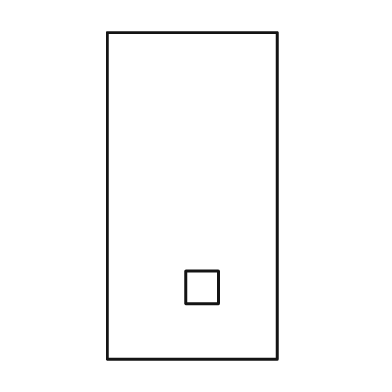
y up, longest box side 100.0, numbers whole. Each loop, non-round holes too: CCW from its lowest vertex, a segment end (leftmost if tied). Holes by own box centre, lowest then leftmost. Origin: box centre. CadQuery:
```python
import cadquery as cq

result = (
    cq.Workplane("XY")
    .moveTo(-26.0, -50.0)
    .lineTo(26.0, -50.0)
    .lineTo(26.0, 50.0)
    .lineTo(-26.0, 50.0)
    .close()
    .moveTo(-2.0, -33.0)
    .lineTo(8.0, -33.0)
    .lineTo(8.0, -23.0)
    .lineTo(-2.0, -23.0)
    .close()
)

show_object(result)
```